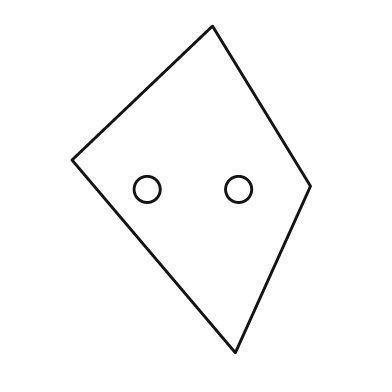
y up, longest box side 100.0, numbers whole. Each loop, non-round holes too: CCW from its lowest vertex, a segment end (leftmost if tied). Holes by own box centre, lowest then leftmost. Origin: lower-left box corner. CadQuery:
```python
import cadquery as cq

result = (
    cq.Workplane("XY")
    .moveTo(50.0, 0.0)
    .lineTo(73.0, 51.0)
    .lineTo(43.0, 100.0)
    .lineTo(0.0, 59.0)
    .close()
    .moveTo(23.0, 50.0)
    .circle(4.0)
    .moveTo(51.0, 50.0)
    .circle(4.0)
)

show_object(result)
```